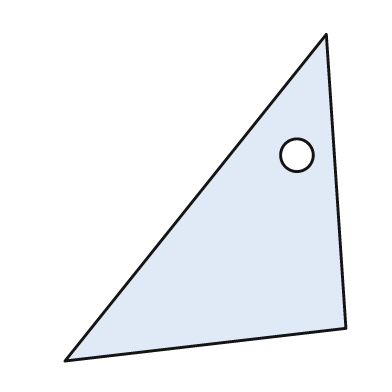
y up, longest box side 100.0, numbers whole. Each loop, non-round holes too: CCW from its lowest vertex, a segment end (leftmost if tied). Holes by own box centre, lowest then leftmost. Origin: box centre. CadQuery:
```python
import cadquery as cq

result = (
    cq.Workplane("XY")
    .moveTo(-43.0, -50.0)
    .lineTo(43.0, -40.0)
    .lineTo(37.0, 50.0)
    .close()
    .moveTo(28.0, 13.0)
    .circle(5.0)
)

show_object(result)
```